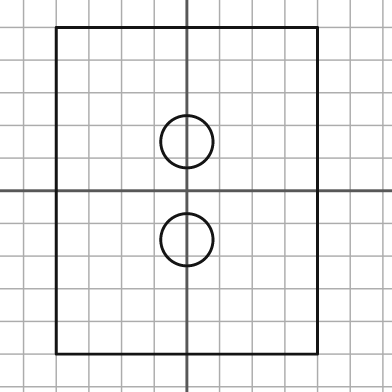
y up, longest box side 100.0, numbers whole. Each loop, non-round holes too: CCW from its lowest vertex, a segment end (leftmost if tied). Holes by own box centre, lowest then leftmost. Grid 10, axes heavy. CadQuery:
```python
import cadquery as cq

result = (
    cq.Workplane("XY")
    .moveTo(-40.0, -50.0)
    .lineTo(40.0, -50.0)
    .lineTo(40.0, 50.0)
    .lineTo(-40.0, 50.0)
    .close()
    .moveTo(0.0, -15.0)
    .circle(8.0)
    .moveTo(0.0, 15.0)
    .circle(8.0)
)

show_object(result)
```